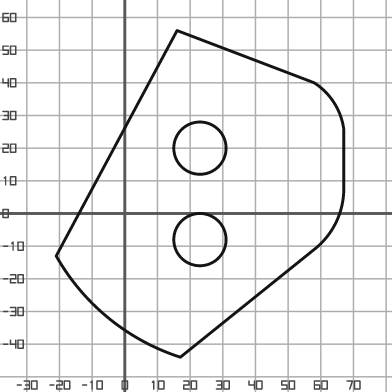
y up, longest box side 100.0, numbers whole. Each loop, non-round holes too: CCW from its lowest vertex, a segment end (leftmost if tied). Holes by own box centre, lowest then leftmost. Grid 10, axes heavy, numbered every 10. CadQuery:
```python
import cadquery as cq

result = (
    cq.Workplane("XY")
    .moveTo(17.0, -44.0)
    .lineTo(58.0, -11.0)
    .threePointArc((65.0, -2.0), (67.0, 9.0))
    .lineTo(67.0, 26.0)
    .threePointArc((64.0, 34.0), (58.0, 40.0))
    .lineTo(16.0, 56.0)
    .lineTo(-21.0, -13.0)
    .threePointArc((-5.0, -32.0), (17.0, -44.0))
    .close()
    .moveTo(23.0, -8.0)
    .circle(8.0)
    .moveTo(23.0, 20.0)
    .circle(8.0)
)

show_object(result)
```